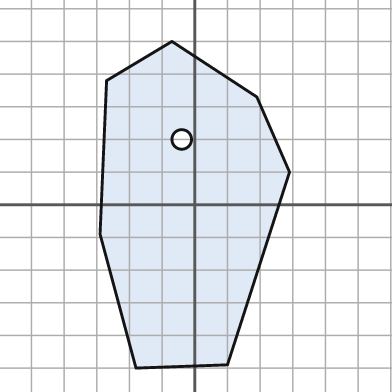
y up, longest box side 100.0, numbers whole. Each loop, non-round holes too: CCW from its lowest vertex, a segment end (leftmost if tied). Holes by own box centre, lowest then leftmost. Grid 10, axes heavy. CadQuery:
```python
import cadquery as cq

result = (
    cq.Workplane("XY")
    .moveTo(-18.0, -50.0)
    .lineTo(10.0, -49.0)
    .lineTo(29.0, 10.0)
    .lineTo(19.0, 33.0)
    .lineTo(-7.0, 50.0)
    .lineTo(-27.0, 38.0)
    .lineTo(-29.0, -9.0)
    .close()
    .moveTo(-4.0, 20.0)
    .circle(3.0)
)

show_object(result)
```